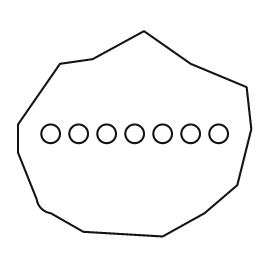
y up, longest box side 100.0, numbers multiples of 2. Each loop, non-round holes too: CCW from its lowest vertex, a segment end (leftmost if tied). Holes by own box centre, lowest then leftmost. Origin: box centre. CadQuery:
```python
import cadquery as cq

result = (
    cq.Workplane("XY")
    .moveTo(12.0, -44.0)
    .lineTo(30.0, -34.0)
    .lineTo(44.0, -22.0)
    .lineTo(50.0, 2.0)
    .lineTo(48.0, 20.0)
    .lineTo(24.0, 30.0)
    .lineTo(4.0, 44.0)
    .lineTo(-18.0, 32.0)
    .lineTo(-32.0, 30.0)
    .lineTo(-50.0, 4.0)
    .lineTo(-50.0, -8.0)
    .lineTo(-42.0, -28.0)
    .threePointArc((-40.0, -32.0), (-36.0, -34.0))
    .lineTo(-22.0, -42.0)
    .close()
    .moveTo(-36.0, 0.0)
    .circle(4.0)
    .moveTo(-24.0, 0.0)
    .circle(4.0)
    .moveTo(-12.0, 0.0)
    .circle(4.0)
    .moveTo(0.0, 0.0)
    .circle(4.0)
    .moveTo(12.0, 0.0)
    .circle(4.0)
    .moveTo(24.0, 0.0)
    .circle(4.0)
    .moveTo(36.0, 0.0)
    .circle(4.0)
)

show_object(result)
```